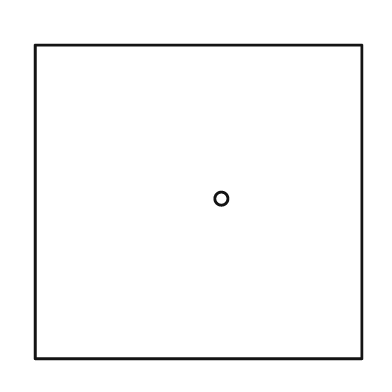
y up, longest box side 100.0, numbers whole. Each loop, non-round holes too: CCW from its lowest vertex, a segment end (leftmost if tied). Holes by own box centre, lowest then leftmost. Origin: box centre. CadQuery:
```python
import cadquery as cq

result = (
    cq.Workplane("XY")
    .moveTo(-50.0, -48.0)
    .lineTo(50.0, -48.0)
    .lineTo(50.0, 48.0)
    .lineTo(-50.0, 48.0)
    .close()
    .moveTo(7.0, 1.0)
    .circle(2.0)
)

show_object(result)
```